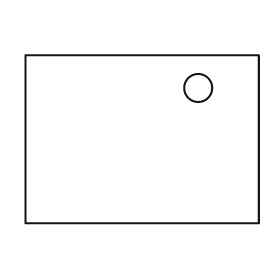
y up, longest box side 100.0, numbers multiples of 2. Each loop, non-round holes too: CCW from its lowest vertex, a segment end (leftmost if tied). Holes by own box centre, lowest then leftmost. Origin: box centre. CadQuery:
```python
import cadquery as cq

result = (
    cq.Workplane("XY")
    .moveTo(-50.0, -36.0)
    .lineTo(50.0, -36.0)
    .lineTo(50.0, 36.0)
    .lineTo(-50.0, 36.0)
    .close()
    .moveTo(24.0, 22.0)
    .circle(6.0)
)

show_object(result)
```